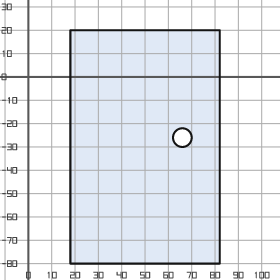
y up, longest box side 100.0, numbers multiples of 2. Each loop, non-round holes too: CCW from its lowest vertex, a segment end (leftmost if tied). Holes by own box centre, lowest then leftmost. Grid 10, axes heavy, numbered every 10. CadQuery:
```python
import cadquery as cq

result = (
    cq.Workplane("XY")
    .moveTo(18.0, -80.0)
    .lineTo(82.0, -80.0)
    .lineTo(82.0, 20.0)
    .lineTo(18.0, 20.0)
    .close()
    .moveTo(66.0, -26.0)
    .circle(4.0)
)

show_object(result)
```